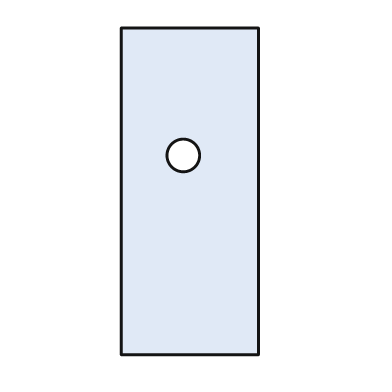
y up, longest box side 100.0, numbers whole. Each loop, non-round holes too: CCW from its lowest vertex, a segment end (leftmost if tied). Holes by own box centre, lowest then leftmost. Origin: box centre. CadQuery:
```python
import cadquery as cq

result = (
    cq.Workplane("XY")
    .moveTo(-21.0, -50.0)
    .lineTo(21.0, -50.0)
    .lineTo(21.0, 50.0)
    .lineTo(-21.0, 50.0)
    .close()
    .moveTo(-2.0, 11.0)
    .circle(5.0)
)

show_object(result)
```